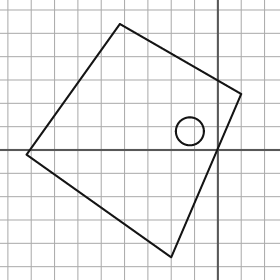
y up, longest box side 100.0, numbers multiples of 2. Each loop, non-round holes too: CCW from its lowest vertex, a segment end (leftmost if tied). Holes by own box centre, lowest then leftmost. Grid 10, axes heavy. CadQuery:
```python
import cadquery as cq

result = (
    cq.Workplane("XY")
    .moveTo(-20.0, -46.0)
    .lineTo(10.0, 24.0)
    .lineTo(-42.0, 54.0)
    .lineTo(-82.0, -2.0)
    .close()
    .moveTo(-12.0, 8.0)
    .circle(6.0)
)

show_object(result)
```